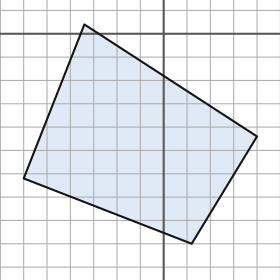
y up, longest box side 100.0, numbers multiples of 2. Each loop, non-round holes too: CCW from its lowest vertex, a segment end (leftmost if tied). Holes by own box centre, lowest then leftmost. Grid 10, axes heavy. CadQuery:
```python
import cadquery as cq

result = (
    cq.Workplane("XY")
    .moveTo(12.0, -90.0)
    .lineTo(40.0, -44.0)
    .lineTo(-34.0, 4.0)
    .lineTo(-60.0, -62.0)
    .close()
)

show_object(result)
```